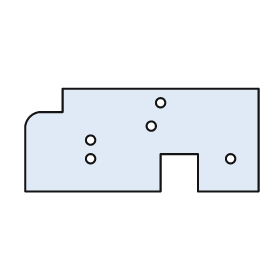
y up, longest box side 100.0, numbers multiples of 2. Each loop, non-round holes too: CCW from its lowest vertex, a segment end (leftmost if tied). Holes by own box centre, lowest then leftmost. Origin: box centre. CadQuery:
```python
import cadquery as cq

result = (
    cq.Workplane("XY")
    .moveTo(-50.0, -22.0)
    .lineTo(8.0, -22.0)
    .lineTo(8.0, -6.0)
    .lineTo(24.0, -6.0)
    .lineTo(24.0, -22.0)
    .lineTo(50.0, -22.0)
    .lineTo(50.0, 22.0)
    .lineTo(-34.0, 22.0)
    .lineTo(-34.0, 12.0)
    .lineTo(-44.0, 12.0)
    .threePointArc((-48.0, 10.0), (-50.0, 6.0))
    .close()
    .moveTo(-22.0, -8.0)
    .circle(2.0)
    .moveTo(38.0, -8.0)
    .circle(2.0)
    .moveTo(-22.0, 0.0)
    .circle(2.0)
    .moveTo(4.0, 6.0)
    .circle(2.0)
    .moveTo(8.0, 16.0)
    .circle(2.0)
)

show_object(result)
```